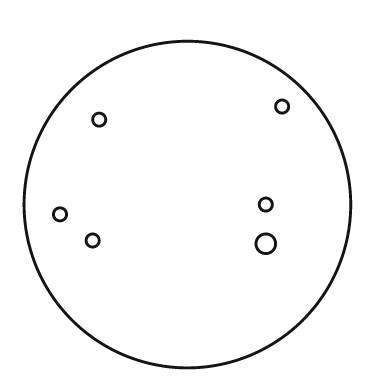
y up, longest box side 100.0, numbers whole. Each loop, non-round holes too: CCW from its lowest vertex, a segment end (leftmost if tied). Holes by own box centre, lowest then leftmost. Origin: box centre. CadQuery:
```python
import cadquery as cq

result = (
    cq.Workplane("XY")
    .moveTo(0.0, 0.0)
    .circle(50.0)
    .moveTo(24.0, -12.0)
    .circle(3.0)
    .moveTo(-29.0, -11.0)
    .circle(2.0)
    .moveTo(-39.0, -3.0)
    .circle(2.0)
    .moveTo(24.0, 0.0)
    .circle(2.0)
    .moveTo(-27.0, 26.0)
    .circle(2.0)
    .moveTo(29.0, 30.0)
    .circle(2.0)
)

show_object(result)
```